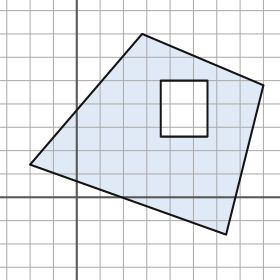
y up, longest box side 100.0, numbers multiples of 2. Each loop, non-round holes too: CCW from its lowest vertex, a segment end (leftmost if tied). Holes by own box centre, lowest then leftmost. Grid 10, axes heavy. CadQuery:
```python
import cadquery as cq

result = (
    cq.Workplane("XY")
    .moveTo(64.0, -16.0)
    .lineTo(80.0, 48.0)
    .lineTo(28.0, 70.0)
    .lineTo(-20.0, 14.0)
    .close()
    .moveTo(36.0, 26.0)
    .lineTo(56.0, 26.0)
    .lineTo(56.0, 50.0)
    .lineTo(36.0, 50.0)
    .close()
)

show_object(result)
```